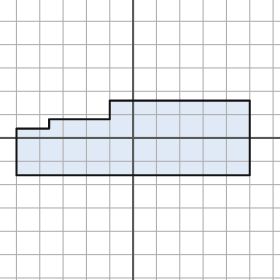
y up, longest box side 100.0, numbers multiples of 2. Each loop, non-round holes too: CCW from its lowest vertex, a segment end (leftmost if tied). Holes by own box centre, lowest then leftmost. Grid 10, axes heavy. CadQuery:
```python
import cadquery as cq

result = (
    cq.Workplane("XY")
    .moveTo(-50.0, -16.0)
    .lineTo(50.0, -16.0)
    .lineTo(50.0, 16.0)
    .lineTo(-10.0, 16.0)
    .lineTo(-10.0, 8.0)
    .lineTo(-36.0, 8.0)
    .lineTo(-36.0, 4.0)
    .lineTo(-50.0, 4.0)
    .close()
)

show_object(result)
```